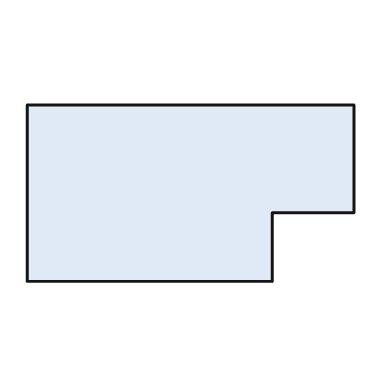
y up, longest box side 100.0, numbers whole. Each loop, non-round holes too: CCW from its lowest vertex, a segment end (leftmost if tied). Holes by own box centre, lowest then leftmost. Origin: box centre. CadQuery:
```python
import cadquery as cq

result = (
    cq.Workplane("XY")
    .moveTo(-50.0, -27.0)
    .lineTo(25.0, -27.0)
    .lineTo(25.0, -6.0)
    .lineTo(50.0, -6.0)
    .lineTo(50.0, 27.0)
    .lineTo(-50.0, 27.0)
    .close()
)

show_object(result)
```